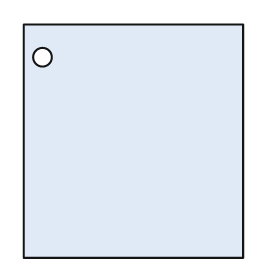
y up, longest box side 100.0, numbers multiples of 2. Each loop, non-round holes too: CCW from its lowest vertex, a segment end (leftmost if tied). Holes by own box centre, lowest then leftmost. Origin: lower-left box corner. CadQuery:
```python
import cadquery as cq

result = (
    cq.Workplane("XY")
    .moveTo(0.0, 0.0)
    .lineTo(94.0, 0.0)
    .lineTo(94.0, 100.0)
    .lineTo(0.0, 100.0)
    .close()
    .moveTo(8.0, 86.0)
    .circle(4.0)
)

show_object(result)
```